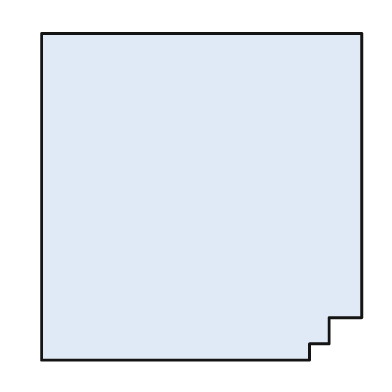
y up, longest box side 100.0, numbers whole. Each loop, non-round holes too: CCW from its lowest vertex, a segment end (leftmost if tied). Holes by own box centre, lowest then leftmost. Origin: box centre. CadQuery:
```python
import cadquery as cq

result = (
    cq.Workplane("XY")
    .moveTo(-49.0, -50.0)
    .lineTo(33.0, -50.0)
    .lineTo(33.0, -45.0)
    .lineTo(39.0, -45.0)
    .lineTo(39.0, -37.0)
    .lineTo(49.0, -37.0)
    .lineTo(49.0, 50.0)
    .lineTo(-49.0, 50.0)
    .close()
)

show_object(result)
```